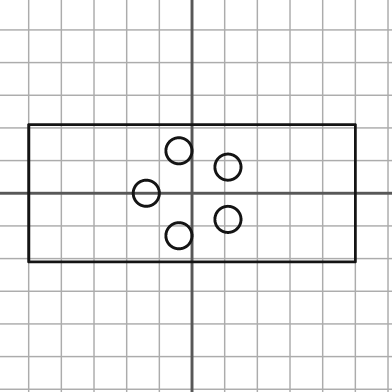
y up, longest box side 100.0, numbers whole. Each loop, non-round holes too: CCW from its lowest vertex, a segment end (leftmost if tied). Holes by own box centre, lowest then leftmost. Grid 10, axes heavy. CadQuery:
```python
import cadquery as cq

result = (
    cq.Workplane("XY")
    .moveTo(-50.0, -21.0)
    .lineTo(50.0, -21.0)
    .lineTo(50.0, 21.0)
    .lineTo(-50.0, 21.0)
    .close()
    .moveTo(-4.0, -13.0)
    .circle(4.0)
    .moveTo(11.0, -8.0)
    .circle(4.0)
    .moveTo(-14.0, 0.0)
    .circle(4.0)
    .moveTo(11.0, 8.0)
    .circle(4.0)
    .moveTo(-4.0, 13.0)
    .circle(4.0)
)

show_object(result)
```